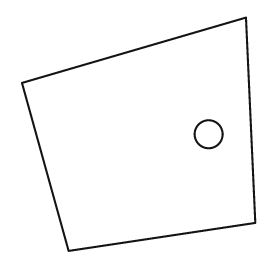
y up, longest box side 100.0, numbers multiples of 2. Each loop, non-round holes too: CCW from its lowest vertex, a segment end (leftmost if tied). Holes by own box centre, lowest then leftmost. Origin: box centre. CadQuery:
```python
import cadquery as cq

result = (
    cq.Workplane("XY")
    .moveTo(-30.0, -50.0)
    .lineTo(50.0, -38.0)
    .lineTo(46.0, 50.0)
    .lineTo(-50.0, 22.0)
    .close()
    .moveTo(30.0, 0.0)
    .circle(6.0)
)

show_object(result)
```